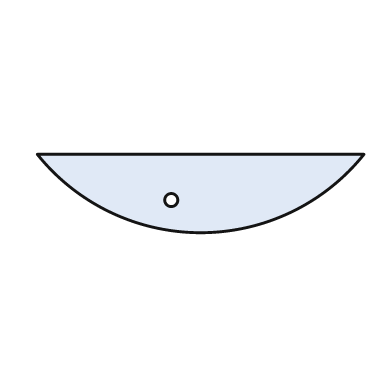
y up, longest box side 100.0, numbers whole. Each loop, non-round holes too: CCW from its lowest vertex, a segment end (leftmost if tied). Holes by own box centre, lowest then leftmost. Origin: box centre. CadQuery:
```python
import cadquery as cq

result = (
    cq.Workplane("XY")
    .moveTo(-50.0, 12.0)
    .threePointArc((0.0, -12.0), (50.0, 12.0))
    .close()
    .moveTo(-9.0, -2.0)
    .circle(2.0)
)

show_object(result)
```